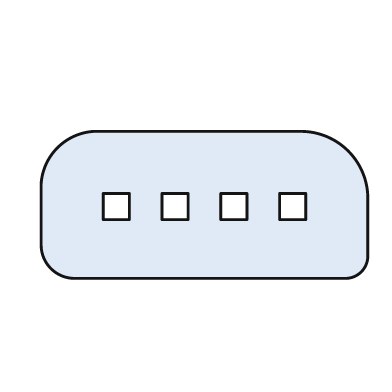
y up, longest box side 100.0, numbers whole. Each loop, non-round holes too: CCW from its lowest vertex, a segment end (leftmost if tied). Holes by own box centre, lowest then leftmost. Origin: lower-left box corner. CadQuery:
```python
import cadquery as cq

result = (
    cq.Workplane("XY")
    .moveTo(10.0, 0.0)
    .lineTo(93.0, 0.0)
    .threePointArc((98.0, 2.0), (100.0, 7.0))
    .lineTo(100.0, 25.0)
    .threePointArc((94.0, 39.0), (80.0, 45.0))
    .lineTo(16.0, 45.0)
    .threePointArc((5.0, 40.0), (0.0, 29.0))
    .lineTo(0.0, 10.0)
    .threePointArc((3.0, 3.0), (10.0, 0.0))
    .close()
    .moveTo(19.0, 18.0)
    .lineTo(27.0, 18.0)
    .lineTo(27.0, 26.0)
    .lineTo(19.0, 26.0)
    .close()
    .moveTo(37.0, 18.0)
    .lineTo(45.0, 18.0)
    .lineTo(45.0, 26.0)
    .lineTo(37.0, 26.0)
    .close()
    .moveTo(55.0, 18.0)
    .lineTo(63.0, 18.0)
    .lineTo(63.0, 26.0)
    .lineTo(55.0, 26.0)
    .close()
    .moveTo(73.0, 18.0)
    .lineTo(81.0, 18.0)
    .lineTo(81.0, 26.0)
    .lineTo(73.0, 26.0)
    .close()
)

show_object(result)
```